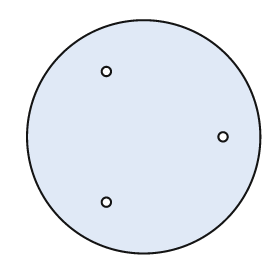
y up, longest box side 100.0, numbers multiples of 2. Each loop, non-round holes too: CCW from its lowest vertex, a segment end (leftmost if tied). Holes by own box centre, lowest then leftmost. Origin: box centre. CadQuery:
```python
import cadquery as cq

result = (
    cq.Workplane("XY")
    .moveTo(0.0, 0.0)
    .circle(50.0)
    .moveTo(-16.0, -28.0)
    .circle(2.0)
    .moveTo(34.0, 0.0)
    .circle(2.0)
    .moveTo(-16.0, 28.0)
    .circle(2.0)
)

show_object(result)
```